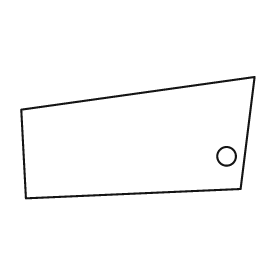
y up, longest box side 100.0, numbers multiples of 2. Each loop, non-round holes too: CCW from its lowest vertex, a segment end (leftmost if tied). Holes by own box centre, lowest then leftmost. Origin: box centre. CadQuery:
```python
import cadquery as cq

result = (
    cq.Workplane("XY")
    .moveTo(-48.0, -26.0)
    .lineTo(44.0, -22.0)
    .lineTo(50.0, 26.0)
    .lineTo(-50.0, 12.0)
    .close()
    .moveTo(38.0, -8.0)
    .circle(4.0)
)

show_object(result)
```